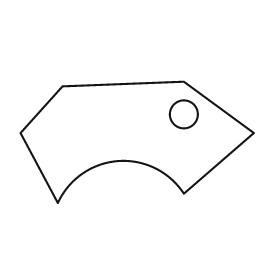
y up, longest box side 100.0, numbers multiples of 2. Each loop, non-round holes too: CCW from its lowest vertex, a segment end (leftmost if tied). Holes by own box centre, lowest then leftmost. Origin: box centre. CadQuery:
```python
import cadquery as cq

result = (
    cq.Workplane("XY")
    .moveTo(-34.0, -26.0)
    .threePointArc((-8.0, -8.0), (20.0, -22.0))
    .lineTo(50.0, 4.0)
    .lineTo(20.0, 26.0)
    .lineTo(-32.0, 24.0)
    .lineTo(-50.0, 4.0)
    .close()
    .moveTo(20.0, 12.0)
    .circle(6.0)
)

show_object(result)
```